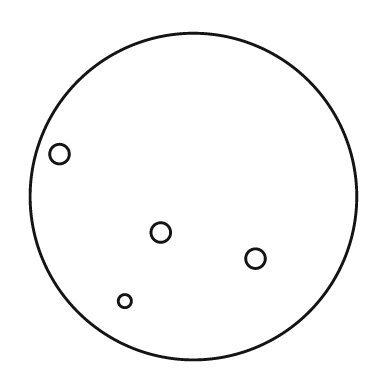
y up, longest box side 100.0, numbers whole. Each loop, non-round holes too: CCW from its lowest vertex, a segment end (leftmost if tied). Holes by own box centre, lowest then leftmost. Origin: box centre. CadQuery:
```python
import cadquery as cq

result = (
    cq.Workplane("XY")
    .moveTo(0.0, 0.0)
    .circle(50.0)
    .moveTo(-21.0, -32.0)
    .circle(2.0)
    .moveTo(19.0, -19.0)
    .circle(3.0)
    .moveTo(-10.0, -11.0)
    .circle(3.0)
    .moveTo(-41.0, 13.0)
    .circle(3.0)
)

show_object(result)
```